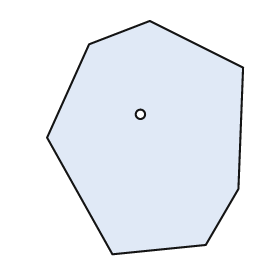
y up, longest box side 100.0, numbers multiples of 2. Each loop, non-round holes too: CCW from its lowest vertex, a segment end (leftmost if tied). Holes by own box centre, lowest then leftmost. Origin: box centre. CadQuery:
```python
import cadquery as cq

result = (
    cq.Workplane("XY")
    .moveTo(-14.0, -50.0)
    .lineTo(26.0, -46.0)
    .lineTo(40.0, -22.0)
    .lineTo(42.0, 30.0)
    .lineTo(2.0, 50.0)
    .lineTo(-24.0, 40.0)
    .lineTo(-42.0, 0.0)
    .close()
    .moveTo(-2.0, 10.0)
    .circle(2.0)
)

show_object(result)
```